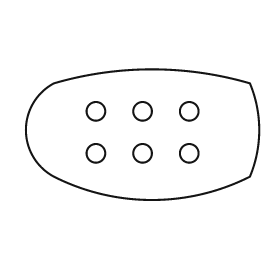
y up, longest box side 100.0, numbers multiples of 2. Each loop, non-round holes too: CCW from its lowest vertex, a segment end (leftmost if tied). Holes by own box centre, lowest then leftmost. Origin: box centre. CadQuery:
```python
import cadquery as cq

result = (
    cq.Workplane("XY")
    .moveTo(-38.0, -18.0)
    .threePointArc((4.0, -28.0), (46.0, -18.0))
    .threePointArc((50.0, 2.0), (46.0, 22.0))
    .threePointArc((4.0, 28.0), (-38.0, 22.0))
    .threePointArc((-50.0, 2.0), (-38.0, -18.0))
    .close()
    .moveTo(-20.0, -8.0)
    .circle(4.0)
    .moveTo(0.0, -8.0)
    .circle(4.0)
    .moveTo(20.0, -8.0)
    .circle(4.0)
    .moveTo(-20.0, 10.0)
    .circle(4.0)
    .moveTo(0.0, 10.0)
    .circle(4.0)
    .moveTo(20.0, 10.0)
    .circle(4.0)
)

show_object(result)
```